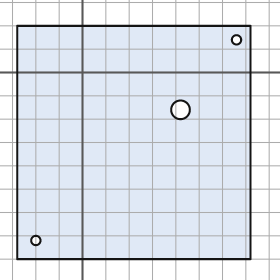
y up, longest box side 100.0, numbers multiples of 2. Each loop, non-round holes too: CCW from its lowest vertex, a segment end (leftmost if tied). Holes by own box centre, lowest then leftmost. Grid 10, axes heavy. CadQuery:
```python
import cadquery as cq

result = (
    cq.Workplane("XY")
    .moveTo(-28.0, -80.0)
    .lineTo(72.0, -80.0)
    .lineTo(72.0, 20.0)
    .lineTo(-28.0, 20.0)
    .close()
    .moveTo(-20.0, -72.0)
    .circle(2.0)
    .moveTo(42.0, -16.0)
    .circle(4.0)
    .moveTo(66.0, 14.0)
    .circle(2.0)
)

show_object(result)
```